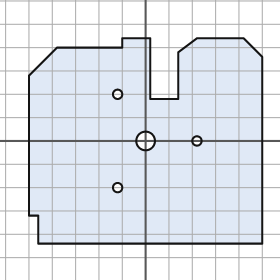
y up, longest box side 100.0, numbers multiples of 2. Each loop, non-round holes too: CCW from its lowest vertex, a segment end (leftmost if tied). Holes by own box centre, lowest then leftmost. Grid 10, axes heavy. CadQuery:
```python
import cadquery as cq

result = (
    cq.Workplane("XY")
    .moveTo(-46.0, -44.0)
    .lineTo(50.0, -44.0)
    .lineTo(50.0, 36.0)
    .lineTo(42.0, 44.0)
    .lineTo(22.0, 44.0)
    .lineTo(14.0, 38.0)
    .lineTo(14.0, 18.0)
    .lineTo(2.0, 18.0)
    .lineTo(2.0, 44.0)
    .lineTo(-10.0, 44.0)
    .lineTo(-10.0, 40.0)
    .lineTo(-38.0, 40.0)
    .lineTo(-50.0, 28.0)
    .lineTo(-50.0, -32.0)
    .lineTo(-46.0, -32.0)
    .close()
    .moveTo(-12.0, -20.0)
    .circle(2.0)
    .moveTo(0.0, 0.0)
    .circle(4.0)
    .moveTo(22.0, 0.0)
    .circle(2.0)
    .moveTo(-12.0, 20.0)
    .circle(2.0)
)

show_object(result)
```